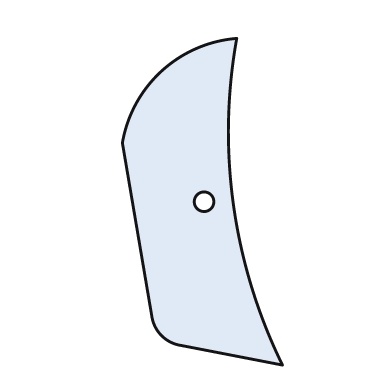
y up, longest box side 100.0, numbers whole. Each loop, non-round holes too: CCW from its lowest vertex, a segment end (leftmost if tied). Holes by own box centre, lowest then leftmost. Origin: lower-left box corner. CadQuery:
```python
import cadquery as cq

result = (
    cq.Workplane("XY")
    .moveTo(49.0, 0.0)
    .threePointArc((34.0, 49.0), (35.0, 100.0))
    .threePointArc((12.0, 90.0), (0.0, 68.0))
    .lineTo(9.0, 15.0)
    .threePointArc((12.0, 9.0), (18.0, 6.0))
    .close()
    .moveTo(25.0, 50.0)
    .circle(3.0)
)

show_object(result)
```